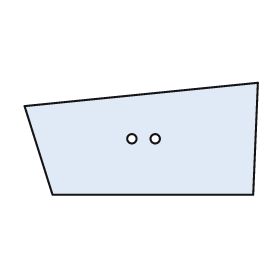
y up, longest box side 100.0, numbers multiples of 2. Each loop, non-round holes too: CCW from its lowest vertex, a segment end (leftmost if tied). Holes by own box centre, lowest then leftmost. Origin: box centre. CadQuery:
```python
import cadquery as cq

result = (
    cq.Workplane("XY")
    .moveTo(-38.0, -24.0)
    .lineTo(48.0, -24.0)
    .lineTo(50.0, 24.0)
    .lineTo(-50.0, 14.0)
    .close()
    .moveTo(-4.0, 0.0)
    .circle(2.0)
    .moveTo(6.0, 0.0)
    .circle(2.0)
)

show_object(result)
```